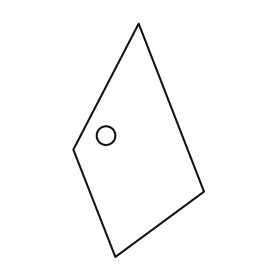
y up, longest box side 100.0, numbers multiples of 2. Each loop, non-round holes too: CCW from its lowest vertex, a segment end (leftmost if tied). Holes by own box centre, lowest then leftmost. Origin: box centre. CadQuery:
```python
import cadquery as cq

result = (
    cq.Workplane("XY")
    .moveTo(-10.0, -50.0)
    .lineTo(28.0, -22.0)
    .lineTo(0.0, 50.0)
    .lineTo(-28.0, -4.0)
    .close()
    .moveTo(-14.0, 2.0)
    .circle(4.0)
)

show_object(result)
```